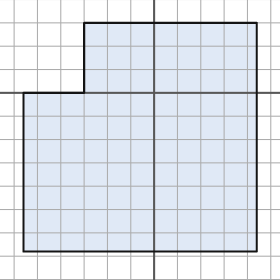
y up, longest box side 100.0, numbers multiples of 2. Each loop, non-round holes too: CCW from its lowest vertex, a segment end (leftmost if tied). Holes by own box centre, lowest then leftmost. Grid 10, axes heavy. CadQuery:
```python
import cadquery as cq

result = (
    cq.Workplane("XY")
    .moveTo(-56.0, -68.0)
    .lineTo(44.0, -68.0)
    .lineTo(44.0, 30.0)
    .lineTo(-30.0, 30.0)
    .lineTo(-30.0, 0.0)
    .lineTo(-56.0, 0.0)
    .close()
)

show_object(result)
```